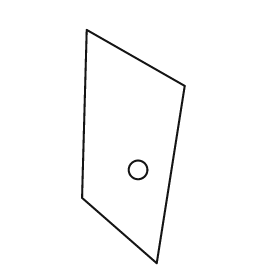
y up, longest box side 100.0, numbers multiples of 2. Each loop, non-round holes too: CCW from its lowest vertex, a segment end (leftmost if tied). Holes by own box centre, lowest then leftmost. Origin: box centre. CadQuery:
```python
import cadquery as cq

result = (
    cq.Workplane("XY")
    .moveTo(10.0, -50.0)
    .lineTo(22.0, 26.0)
    .lineTo(-20.0, 50.0)
    .lineTo(-22.0, -22.0)
    .close()
    .moveTo(2.0, -10.0)
    .circle(4.0)
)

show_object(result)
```